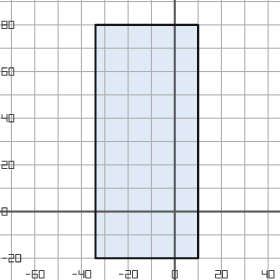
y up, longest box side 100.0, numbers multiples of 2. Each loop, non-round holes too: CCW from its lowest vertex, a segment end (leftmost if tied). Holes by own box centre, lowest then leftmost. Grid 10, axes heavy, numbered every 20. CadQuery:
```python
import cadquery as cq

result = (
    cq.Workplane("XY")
    .moveTo(-34.0, -20.0)
    .lineTo(10.0, -20.0)
    .lineTo(10.0, 80.0)
    .lineTo(-34.0, 80.0)
    .close()
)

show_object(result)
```